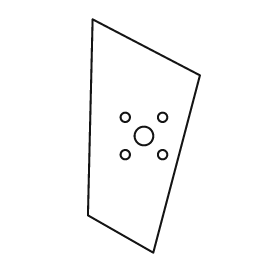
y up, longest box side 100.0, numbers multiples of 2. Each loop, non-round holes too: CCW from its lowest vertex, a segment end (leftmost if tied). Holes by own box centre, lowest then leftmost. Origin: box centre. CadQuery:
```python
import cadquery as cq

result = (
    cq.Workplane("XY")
    .moveTo(4.0, -50.0)
    .lineTo(24.0, 26.0)
    .lineTo(-22.0, 50.0)
    .lineTo(-24.0, -34.0)
    .close()
    .moveTo(-8.0, -8.0)
    .circle(2.0)
    .moveTo(8.0, -8.0)
    .circle(2.0)
    .moveTo(0.0, 0.0)
    .circle(4.0)
    .moveTo(-8.0, 8.0)
    .circle(2.0)
    .moveTo(8.0, 8.0)
    .circle(2.0)
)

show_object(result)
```